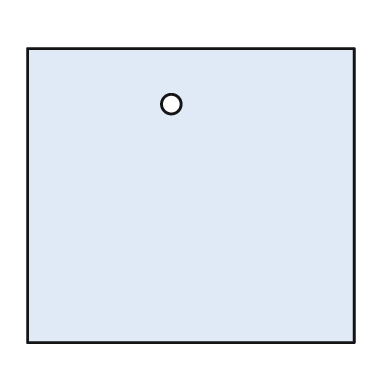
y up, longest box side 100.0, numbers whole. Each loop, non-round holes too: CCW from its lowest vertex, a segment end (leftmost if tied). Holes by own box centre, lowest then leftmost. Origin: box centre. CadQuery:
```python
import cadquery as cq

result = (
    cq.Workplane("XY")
    .moveTo(-50.0, -45.0)
    .lineTo(50.0, -45.0)
    .lineTo(50.0, 45.0)
    .lineTo(-50.0, 45.0)
    .close()
    .moveTo(-6.0, 28.0)
    .circle(3.0)
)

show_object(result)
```